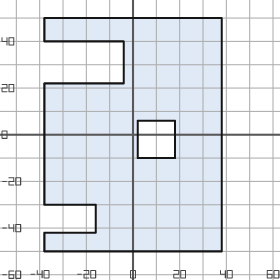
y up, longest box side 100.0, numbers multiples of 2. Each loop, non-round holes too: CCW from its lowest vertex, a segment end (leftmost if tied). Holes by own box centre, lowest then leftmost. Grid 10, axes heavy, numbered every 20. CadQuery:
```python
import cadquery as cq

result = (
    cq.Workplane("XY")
    .moveTo(-38.0, -50.0)
    .lineTo(38.0, -50.0)
    .lineTo(38.0, 50.0)
    .lineTo(-38.0, 50.0)
    .lineTo(-38.0, 40.0)
    .lineTo(-4.0, 40.0)
    .lineTo(-4.0, 22.0)
    .lineTo(-38.0, 22.0)
    .lineTo(-38.0, -30.0)
    .lineTo(-16.0, -30.0)
    .lineTo(-16.0, -42.0)
    .lineTo(-38.0, -42.0)
    .close()
    .moveTo(2.0, -10.0)
    .lineTo(18.0, -10.0)
    .lineTo(18.0, 6.0)
    .lineTo(2.0, 6.0)
    .close()
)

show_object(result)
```